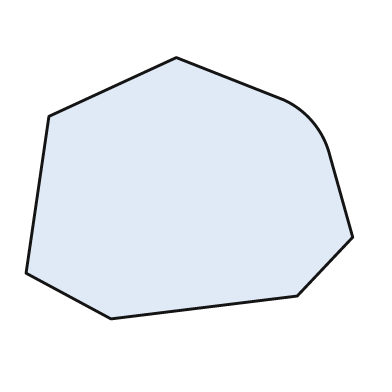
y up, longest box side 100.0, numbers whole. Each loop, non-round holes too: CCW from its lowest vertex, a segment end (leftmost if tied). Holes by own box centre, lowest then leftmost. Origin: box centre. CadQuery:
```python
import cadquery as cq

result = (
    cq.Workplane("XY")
    .moveTo(-24.0, -40.0)
    .lineTo(33.0, -33.0)
    .lineTo(50.0, -15.0)
    .lineTo(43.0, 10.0)
    .threePointArc((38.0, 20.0), (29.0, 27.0))
    .lineTo(-4.0, 40.0)
    .lineTo(-43.0, 22.0)
    .lineTo(-50.0, -26.0)
    .close()
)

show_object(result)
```